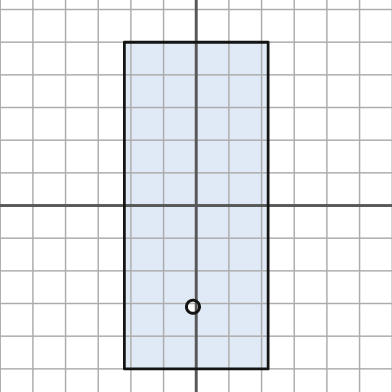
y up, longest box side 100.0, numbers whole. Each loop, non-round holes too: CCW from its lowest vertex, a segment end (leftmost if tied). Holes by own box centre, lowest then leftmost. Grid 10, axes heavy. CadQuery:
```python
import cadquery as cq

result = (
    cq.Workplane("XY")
    .moveTo(-22.0, -50.0)
    .lineTo(22.0, -50.0)
    .lineTo(22.0, 50.0)
    .lineTo(-22.0, 50.0)
    .close()
    .moveTo(-1.0, -31.0)
    .circle(2.0)
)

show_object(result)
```